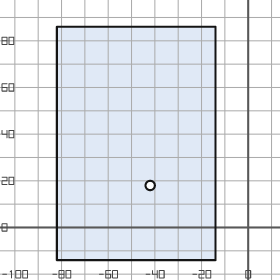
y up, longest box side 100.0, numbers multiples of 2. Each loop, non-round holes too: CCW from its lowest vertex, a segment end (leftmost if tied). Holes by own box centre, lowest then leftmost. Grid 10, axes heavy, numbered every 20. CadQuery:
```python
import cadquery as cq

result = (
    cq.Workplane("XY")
    .moveTo(-82.0, -14.0)
    .lineTo(-14.0, -14.0)
    .lineTo(-14.0, 86.0)
    .lineTo(-82.0, 86.0)
    .close()
    .moveTo(-42.0, 18.0)
    .circle(2.0)
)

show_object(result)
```